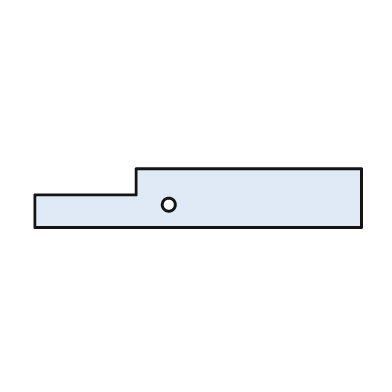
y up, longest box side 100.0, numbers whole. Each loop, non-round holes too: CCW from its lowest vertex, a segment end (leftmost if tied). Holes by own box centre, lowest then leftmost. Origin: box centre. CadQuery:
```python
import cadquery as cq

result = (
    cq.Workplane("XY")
    .moveTo(-50.0, -9.0)
    .lineTo(50.0, -9.0)
    .lineTo(50.0, 9.0)
    .lineTo(-19.0, 9.0)
    .lineTo(-19.0, 1.0)
    .lineTo(-50.0, 1.0)
    .close()
    .moveTo(-9.0, -2.0)
    .circle(2.0)
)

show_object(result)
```